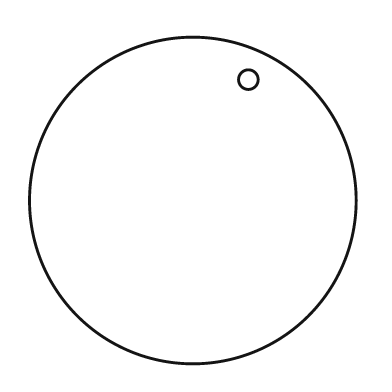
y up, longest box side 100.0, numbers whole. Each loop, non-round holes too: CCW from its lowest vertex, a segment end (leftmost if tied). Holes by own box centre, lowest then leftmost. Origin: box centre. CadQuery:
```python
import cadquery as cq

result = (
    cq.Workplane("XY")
    .moveTo(0.0, 0.0)
    .circle(50.0)
    .moveTo(17.0, 37.0)
    .circle(3.0)
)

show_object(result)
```